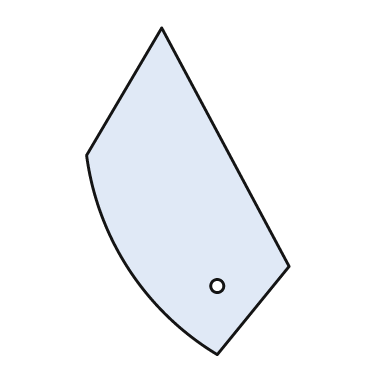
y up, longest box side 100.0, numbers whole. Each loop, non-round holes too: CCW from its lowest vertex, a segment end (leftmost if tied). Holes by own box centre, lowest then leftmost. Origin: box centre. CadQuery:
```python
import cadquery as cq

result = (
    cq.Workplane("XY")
    .moveTo(9.0, -50.0)
    .lineTo(31.0, -23.0)
    .lineTo(-8.0, 50.0)
    .lineTo(-31.0, 11.0)
    .threePointArc((-18.0, -24.0), (9.0, -50.0))
    .close()
    .moveTo(9.0, -29.0)
    .circle(2.0)
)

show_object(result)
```